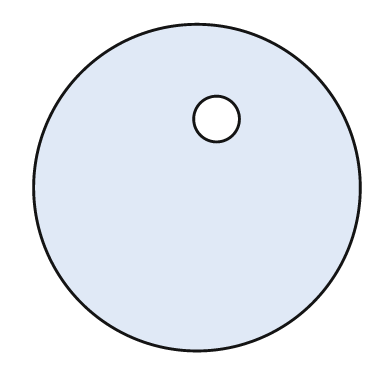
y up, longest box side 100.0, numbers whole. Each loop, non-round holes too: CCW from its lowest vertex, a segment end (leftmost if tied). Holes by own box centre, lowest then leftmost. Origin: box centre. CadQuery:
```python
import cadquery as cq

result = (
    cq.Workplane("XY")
    .moveTo(0.0, 0.0)
    .circle(50.0)
    .moveTo(6.0, 21.0)
    .circle(7.0)
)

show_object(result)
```